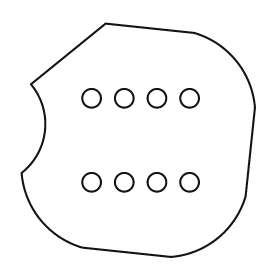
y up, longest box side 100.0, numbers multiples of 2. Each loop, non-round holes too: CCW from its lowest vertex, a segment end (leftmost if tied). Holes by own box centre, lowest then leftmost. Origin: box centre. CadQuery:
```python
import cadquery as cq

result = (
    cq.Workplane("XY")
    .moveTo(14.0, -50.0)
    .threePointArc((34.0, -42.0), (46.0, -24.0))
    .lineTo(50.0, 14.0)
    .threePointArc((42.0, 34.0), (24.0, 46.0))
    .lineTo(-14.0, 50.0)
    .lineTo(-46.0, 24.0)
    .threePointArc((-40.0, 4.0), (-50.0, -14.0))
    .threePointArc((-42.0, -34.0), (-24.0, -46.0))
    .close()
    .moveTo(-20.0, -18.0)
    .circle(4.0)
    .moveTo(-6.0, -18.0)
    .circle(4.0)
    .moveTo(8.0, -18.0)
    .circle(4.0)
    .moveTo(22.0, -18.0)
    .circle(4.0)
    .moveTo(-20.0, 18.0)
    .circle(4.0)
    .moveTo(-6.0, 18.0)
    .circle(4.0)
    .moveTo(8.0, 18.0)
    .circle(4.0)
    .moveTo(22.0, 18.0)
    .circle(4.0)
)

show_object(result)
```